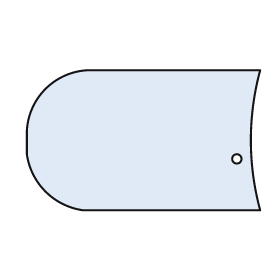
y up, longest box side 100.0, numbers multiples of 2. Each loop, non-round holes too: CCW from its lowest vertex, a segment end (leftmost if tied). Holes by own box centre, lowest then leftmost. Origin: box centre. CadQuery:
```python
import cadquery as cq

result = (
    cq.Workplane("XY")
    .moveTo(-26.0, -30.0)
    .lineTo(50.0, -30.0)
    .threePointArc((46.0, 0.0), (50.0, 30.0))
    .lineTo(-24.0, 30.0)
    .threePointArc((-42.0, 22.0), (-50.0, 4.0))
    .lineTo(-50.0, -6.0)
    .threePointArc((-42.0, -22.0), (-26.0, -30.0))
    .close()
    .moveTo(40.0, -8.0)
    .circle(2.0)
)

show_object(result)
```